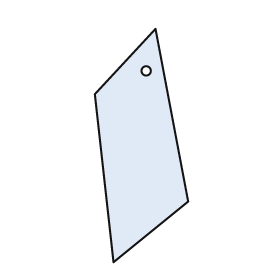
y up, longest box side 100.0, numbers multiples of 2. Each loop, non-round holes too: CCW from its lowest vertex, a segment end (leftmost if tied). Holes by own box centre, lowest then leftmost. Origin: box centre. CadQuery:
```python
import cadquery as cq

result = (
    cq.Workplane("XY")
    .moveTo(-12.0, -50.0)
    .lineTo(20.0, -24.0)
    .lineTo(6.0, 50.0)
    .lineTo(-20.0, 22.0)
    .close()
    .moveTo(2.0, 32.0)
    .circle(2.0)
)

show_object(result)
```